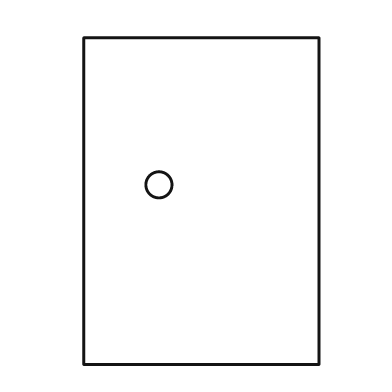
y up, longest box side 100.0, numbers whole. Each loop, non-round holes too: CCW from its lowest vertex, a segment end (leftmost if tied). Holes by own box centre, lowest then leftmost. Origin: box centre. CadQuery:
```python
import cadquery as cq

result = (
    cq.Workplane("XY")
    .moveTo(-36.0, -50.0)
    .lineTo(36.0, -50.0)
    .lineTo(36.0, 50.0)
    .lineTo(-36.0, 50.0)
    .close()
    .moveTo(-13.0, 5.0)
    .circle(4.0)
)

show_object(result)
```